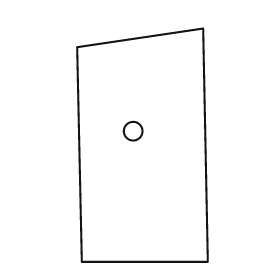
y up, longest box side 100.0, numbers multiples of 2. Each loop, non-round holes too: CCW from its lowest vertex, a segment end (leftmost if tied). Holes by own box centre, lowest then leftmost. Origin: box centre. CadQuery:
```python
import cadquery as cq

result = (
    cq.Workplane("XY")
    .moveTo(-26.0, -50.0)
    .lineTo(28.0, -50.0)
    .lineTo(26.0, 50.0)
    .lineTo(-28.0, 42.0)
    .close()
    .moveTo(-4.0, 6.0)
    .circle(4.0)
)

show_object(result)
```